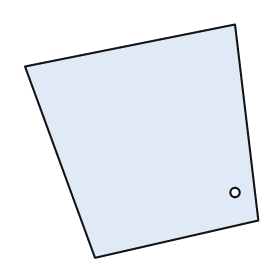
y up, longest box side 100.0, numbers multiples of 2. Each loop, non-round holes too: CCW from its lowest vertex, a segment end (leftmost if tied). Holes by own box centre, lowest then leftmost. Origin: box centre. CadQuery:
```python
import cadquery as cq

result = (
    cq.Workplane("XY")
    .moveTo(-20.0, -50.0)
    .lineTo(50.0, -34.0)
    .lineTo(40.0, 50.0)
    .lineTo(-50.0, 32.0)
    .close()
    .moveTo(40.0, -22.0)
    .circle(2.0)
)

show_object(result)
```